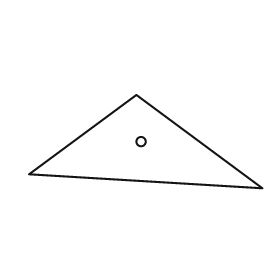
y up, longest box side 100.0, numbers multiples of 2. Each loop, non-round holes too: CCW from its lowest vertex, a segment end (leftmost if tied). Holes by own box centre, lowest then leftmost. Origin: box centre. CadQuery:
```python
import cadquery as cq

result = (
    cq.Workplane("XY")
    .moveTo(50.0, -20.0)
    .lineTo(-4.0, 20.0)
    .lineTo(-50.0, -14.0)
    .close()
    .moveTo(-2.0, 0.0)
    .circle(2.0)
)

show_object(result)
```